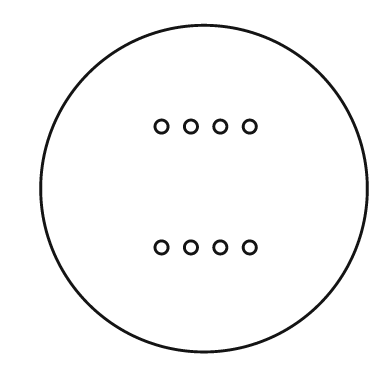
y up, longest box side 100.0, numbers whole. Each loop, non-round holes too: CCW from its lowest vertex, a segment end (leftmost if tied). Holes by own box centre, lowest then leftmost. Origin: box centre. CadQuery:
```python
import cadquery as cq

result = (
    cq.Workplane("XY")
    .moveTo(0.0, 0.0)
    .circle(50.0)
    .moveTo(-13.0, -18.0)
    .circle(2.0)
    .moveTo(-4.0, -18.0)
    .circle(2.0)
    .moveTo(5.0, -18.0)
    .circle(2.0)
    .moveTo(14.0, -18.0)
    .circle(2.0)
    .moveTo(-13.0, 19.0)
    .circle(2.0)
    .moveTo(-4.0, 19.0)
    .circle(2.0)
    .moveTo(5.0, 19.0)
    .circle(2.0)
    .moveTo(14.0, 19.0)
    .circle(2.0)
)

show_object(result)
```